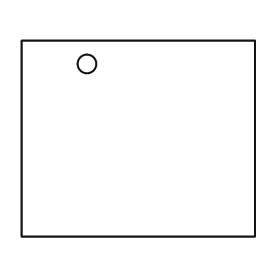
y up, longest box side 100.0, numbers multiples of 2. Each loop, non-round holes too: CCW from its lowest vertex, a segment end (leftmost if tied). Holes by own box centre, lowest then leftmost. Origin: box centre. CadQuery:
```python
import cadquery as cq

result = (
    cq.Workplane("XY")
    .moveTo(-50.0, -42.0)
    .lineTo(50.0, -42.0)
    .lineTo(50.0, 42.0)
    .lineTo(-50.0, 42.0)
    .close()
    .moveTo(-22.0, 32.0)
    .circle(4.0)
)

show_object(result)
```